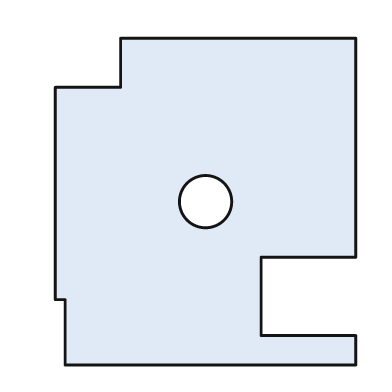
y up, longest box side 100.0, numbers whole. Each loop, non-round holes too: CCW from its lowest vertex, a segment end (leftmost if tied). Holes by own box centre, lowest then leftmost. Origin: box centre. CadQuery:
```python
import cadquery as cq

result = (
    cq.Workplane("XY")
    .moveTo(-43.0, -50.0)
    .lineTo(46.0, -50.0)
    .lineTo(46.0, -41.0)
    .lineTo(17.0, -41.0)
    .lineTo(17.0, -17.0)
    .lineTo(46.0, -17.0)
    .lineTo(46.0, 50.0)
    .lineTo(-26.0, 50.0)
    .lineTo(-26.0, 35.0)
    .lineTo(-46.0, 35.0)
    .lineTo(-46.0, -30.0)
    .lineTo(-43.0, -30.0)
    .close()
    .moveTo(0.0, 0.0)
    .circle(8.0)
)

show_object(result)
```